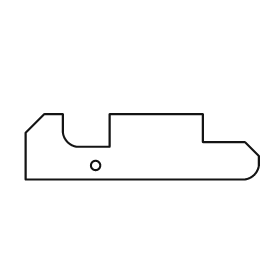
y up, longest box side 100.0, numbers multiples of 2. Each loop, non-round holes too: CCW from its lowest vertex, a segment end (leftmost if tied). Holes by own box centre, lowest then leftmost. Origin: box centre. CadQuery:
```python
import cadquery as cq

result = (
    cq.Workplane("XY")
    .moveTo(-50.0, -14.0)
    .lineTo(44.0, -14.0)
    .threePointArc((48.0, -12.0), (50.0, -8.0))
    .lineTo(50.0, -4.0)
    .lineTo(44.0, 2.0)
    .lineTo(26.0, 2.0)
    .lineTo(26.0, 14.0)
    .lineTo(-14.0, 14.0)
    .lineTo(-14.0, 0.0)
    .lineTo(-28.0, 0.0)
    .threePointArc((-32.0, 2.0), (-34.0, 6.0))
    .lineTo(-34.0, 14.0)
    .lineTo(-42.0, 14.0)
    .lineTo(-50.0, 6.0)
    .close()
    .moveTo(-20.0, -8.0)
    .circle(2.0)
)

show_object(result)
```